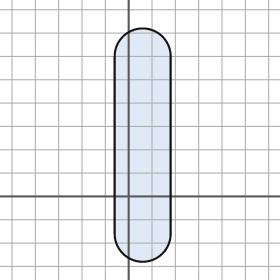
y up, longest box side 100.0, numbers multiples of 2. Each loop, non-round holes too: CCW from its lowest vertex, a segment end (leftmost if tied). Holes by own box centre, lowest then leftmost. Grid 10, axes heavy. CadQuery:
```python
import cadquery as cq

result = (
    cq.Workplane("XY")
    .moveTo(-6.0, -16.0)
    .threePointArc((6.0, -28.0), (18.0, -16.0))
    .lineTo(18.0, 60.0)
    .threePointArc((6.0, 72.0), (-6.0, 60.0))
    .close()
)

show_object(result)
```